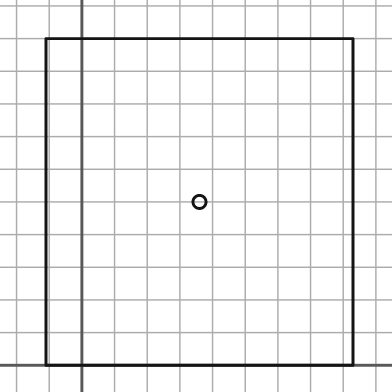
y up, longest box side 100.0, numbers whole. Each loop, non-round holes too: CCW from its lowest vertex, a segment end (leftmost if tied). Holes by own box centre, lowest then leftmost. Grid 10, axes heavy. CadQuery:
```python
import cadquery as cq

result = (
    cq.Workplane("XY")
    .moveTo(-11.0, 0.0)
    .lineTo(83.0, 0.0)
    .lineTo(83.0, 100.0)
    .lineTo(-11.0, 100.0)
    .close()
    .moveTo(36.0, 50.0)
    .circle(2.0)
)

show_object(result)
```